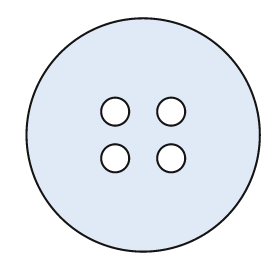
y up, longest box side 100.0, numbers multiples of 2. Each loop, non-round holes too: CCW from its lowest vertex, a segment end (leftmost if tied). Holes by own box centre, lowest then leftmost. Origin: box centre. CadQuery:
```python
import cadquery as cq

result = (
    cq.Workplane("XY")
    .moveTo(0.0, 0.0)
    .circle(50.0)
    .moveTo(-12.0, -10.0)
    .circle(6.0)
    .moveTo(12.0, -10.0)
    .circle(6.0)
    .moveTo(-12.0, 10.0)
    .circle(6.0)
    .moveTo(12.0, 10.0)
    .circle(6.0)
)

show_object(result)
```